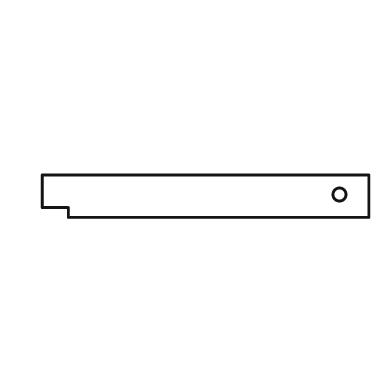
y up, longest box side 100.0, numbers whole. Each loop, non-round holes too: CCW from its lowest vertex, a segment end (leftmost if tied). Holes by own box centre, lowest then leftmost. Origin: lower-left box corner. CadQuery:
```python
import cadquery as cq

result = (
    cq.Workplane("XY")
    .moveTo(8.0, 0.0)
    .lineTo(100.0, 0.0)
    .lineTo(100.0, 13.0)
    .lineTo(0.0, 13.0)
    .lineTo(0.0, 3.0)
    .lineTo(8.0, 3.0)
    .close()
    .moveTo(91.0, 7.0)
    .circle(2.0)
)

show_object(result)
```